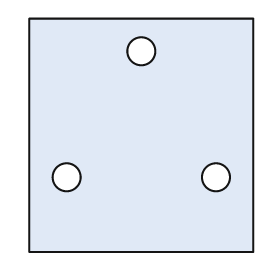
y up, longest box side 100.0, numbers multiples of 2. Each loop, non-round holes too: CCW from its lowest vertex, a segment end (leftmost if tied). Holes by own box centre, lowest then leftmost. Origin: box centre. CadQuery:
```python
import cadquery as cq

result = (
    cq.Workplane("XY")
    .moveTo(-48.0, -50.0)
    .lineTo(48.0, -50.0)
    .lineTo(48.0, 50.0)
    .lineTo(-48.0, 50.0)
    .close()
    .moveTo(-32.0, -18.0)
    .circle(6.0)
    .moveTo(32.0, -18.0)
    .circle(6.0)
    .moveTo(0.0, 36.0)
    .circle(6.0)
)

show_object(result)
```